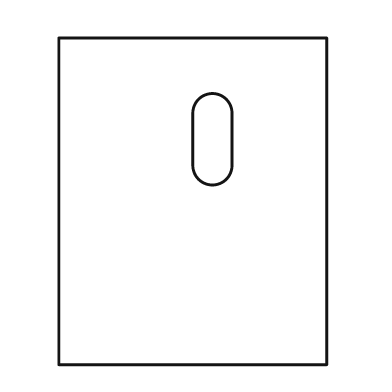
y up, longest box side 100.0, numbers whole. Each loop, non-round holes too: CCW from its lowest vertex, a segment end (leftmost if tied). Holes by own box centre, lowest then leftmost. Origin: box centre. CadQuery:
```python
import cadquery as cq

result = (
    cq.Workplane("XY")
    .moveTo(-41.0, -50.0)
    .lineTo(41.0, -50.0)
    .lineTo(41.0, 50.0)
    .lineTo(-41.0, 50.0)
    .close()
    .moveTo(0.0, 11.0)
    .threePointArc((6.0, 5.0), (12.0, 11.0))
    .lineTo(12.0, 27.0)
    .threePointArc((6.0, 33.0), (0.0, 27.0))
    .close()
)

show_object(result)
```